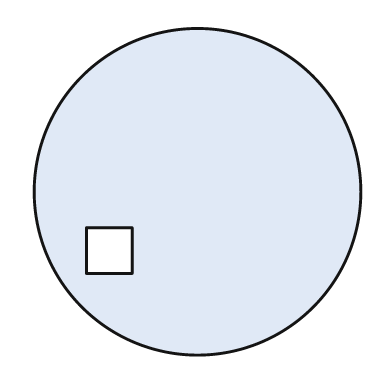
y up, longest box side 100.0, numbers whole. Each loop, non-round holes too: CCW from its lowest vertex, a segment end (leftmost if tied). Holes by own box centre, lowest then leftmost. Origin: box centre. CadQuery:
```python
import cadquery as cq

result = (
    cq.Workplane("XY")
    .moveTo(0.0, 0.0)
    .circle(50.0)
    .moveTo(-34.0, -25.0)
    .lineTo(-20.0, -25.0)
    .lineTo(-20.0, -11.0)
    .lineTo(-34.0, -11.0)
    .close()
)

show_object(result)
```